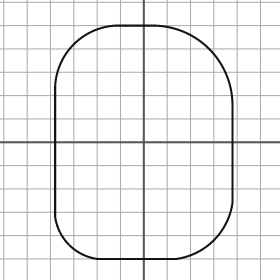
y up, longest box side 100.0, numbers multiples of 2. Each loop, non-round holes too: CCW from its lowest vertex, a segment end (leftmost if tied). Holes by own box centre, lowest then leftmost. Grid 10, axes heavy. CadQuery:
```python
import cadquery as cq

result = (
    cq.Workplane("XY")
    .moveTo(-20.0, -50.0)
    .lineTo(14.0, -50.0)
    .threePointArc((30.0, -42.0), (38.0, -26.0))
    .lineTo(38.0, 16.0)
    .threePointArc((28.0, 40.0), (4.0, 50.0))
    .lineTo(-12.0, 50.0)
    .threePointArc((-30.0, 42.0), (-38.0, 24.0))
    .lineTo(-38.0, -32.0)
    .threePointArc((-32.0, -44.0), (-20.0, -50.0))
    .close()
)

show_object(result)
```